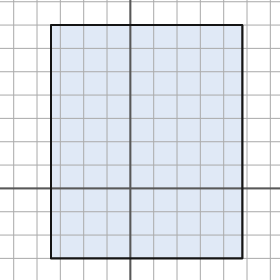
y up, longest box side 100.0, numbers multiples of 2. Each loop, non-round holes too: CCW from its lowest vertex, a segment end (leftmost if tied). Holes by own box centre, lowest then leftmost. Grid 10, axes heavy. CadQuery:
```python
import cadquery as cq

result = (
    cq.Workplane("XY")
    .moveTo(-34.0, -30.0)
    .lineTo(48.0, -30.0)
    .lineTo(48.0, 70.0)
    .lineTo(-34.0, 70.0)
    .close()
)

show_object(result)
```